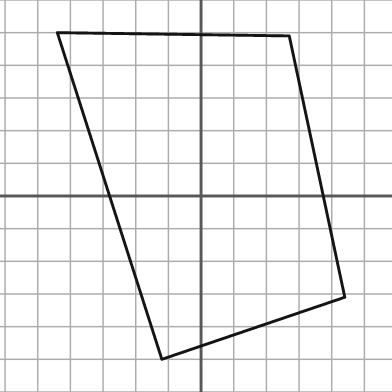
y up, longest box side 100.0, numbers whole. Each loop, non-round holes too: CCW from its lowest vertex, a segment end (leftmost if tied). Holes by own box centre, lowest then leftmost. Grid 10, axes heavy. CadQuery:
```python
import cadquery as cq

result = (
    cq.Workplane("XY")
    .moveTo(-12.0, -50.0)
    .lineTo(44.0, -31.0)
    .lineTo(27.0, 49.0)
    .lineTo(-44.0, 50.0)
    .close()
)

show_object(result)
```